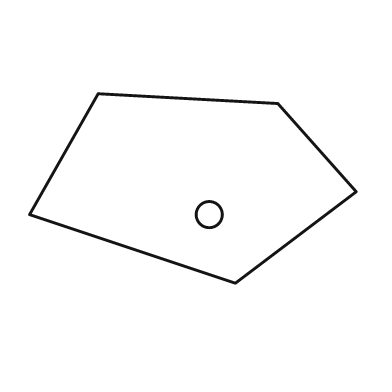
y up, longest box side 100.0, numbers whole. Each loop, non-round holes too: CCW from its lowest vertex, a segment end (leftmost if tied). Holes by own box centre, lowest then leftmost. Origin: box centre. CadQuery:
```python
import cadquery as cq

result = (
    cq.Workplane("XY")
    .moveTo(13.0, -29.0)
    .lineTo(50.0, -1.0)
    .lineTo(26.0, 26.0)
    .lineTo(-29.0, 29.0)
    .lineTo(-50.0, -8.0)
    .close()
    .moveTo(5.0, -8.0)
    .circle(4.0)
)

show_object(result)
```